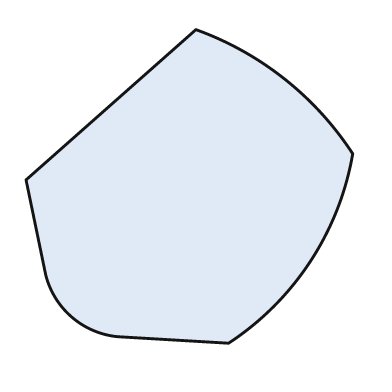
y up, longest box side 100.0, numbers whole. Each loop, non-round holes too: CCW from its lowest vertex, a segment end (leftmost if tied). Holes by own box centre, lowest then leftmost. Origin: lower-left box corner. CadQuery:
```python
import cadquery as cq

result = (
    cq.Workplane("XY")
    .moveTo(62.0, 0.0)
    .threePointArc((87.0, 25.0), (100.0, 58.0))
    .threePointArc((79.0, 81.0), (52.0, 96.0))
    .lineTo(0.0, 50.0)
    .lineTo(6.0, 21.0)
    .threePointArc((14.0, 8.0), (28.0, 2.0))
    .close()
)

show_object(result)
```